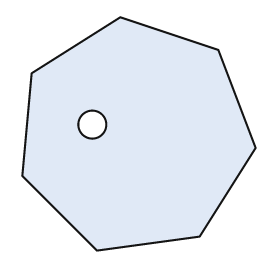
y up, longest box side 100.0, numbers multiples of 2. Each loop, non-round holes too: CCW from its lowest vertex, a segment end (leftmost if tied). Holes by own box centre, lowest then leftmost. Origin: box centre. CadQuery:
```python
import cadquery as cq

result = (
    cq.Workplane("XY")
    .moveTo(-18.0, -50.0)
    .lineTo(26.0, -44.0)
    .lineTo(50.0, -6.0)
    .lineTo(34.0, 36.0)
    .lineTo(-8.0, 50.0)
    .lineTo(-46.0, 26.0)
    .lineTo(-50.0, -18.0)
    .close()
    .moveTo(-20.0, 4.0)
    .circle(6.0)
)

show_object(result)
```